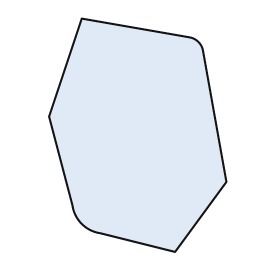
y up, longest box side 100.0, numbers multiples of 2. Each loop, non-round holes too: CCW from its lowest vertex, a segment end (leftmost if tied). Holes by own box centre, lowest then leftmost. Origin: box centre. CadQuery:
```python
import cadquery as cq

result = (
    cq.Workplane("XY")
    .moveTo(16.0, -50.0)
    .lineTo(38.0, -20.0)
    .lineTo(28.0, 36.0)
    .threePointArc((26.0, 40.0), (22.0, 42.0))
    .lineTo(-24.0, 50.0)
    .lineTo(-38.0, 8.0)
    .lineTo(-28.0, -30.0)
    .threePointArc((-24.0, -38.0), (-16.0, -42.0))
    .close()
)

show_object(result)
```